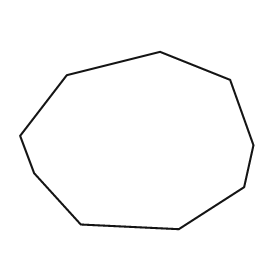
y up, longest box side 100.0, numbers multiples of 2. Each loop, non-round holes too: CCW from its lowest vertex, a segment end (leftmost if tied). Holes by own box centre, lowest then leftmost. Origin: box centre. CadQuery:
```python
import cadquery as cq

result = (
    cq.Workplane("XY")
    .moveTo(18.0, -38.0)
    .lineTo(46.0, -20.0)
    .lineTo(50.0, -2.0)
    .lineTo(40.0, 26.0)
    .lineTo(10.0, 38.0)
    .lineTo(-30.0, 28.0)
    .lineTo(-50.0, 2.0)
    .lineTo(-44.0, -14.0)
    .lineTo(-24.0, -36.0)
    .close()
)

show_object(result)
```